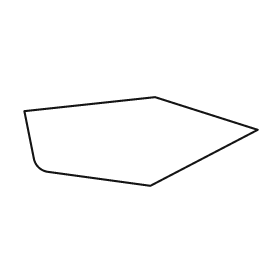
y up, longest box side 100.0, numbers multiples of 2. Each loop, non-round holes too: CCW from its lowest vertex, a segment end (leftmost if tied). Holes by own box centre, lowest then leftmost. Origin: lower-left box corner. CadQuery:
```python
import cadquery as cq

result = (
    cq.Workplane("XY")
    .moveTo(54.0, 0.0)
    .lineTo(100.0, 24.0)
    .lineTo(56.0, 38.0)
    .lineTo(0.0, 32.0)
    .lineTo(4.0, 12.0)
    .threePointArc((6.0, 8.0), (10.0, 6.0))
    .close()
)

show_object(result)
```